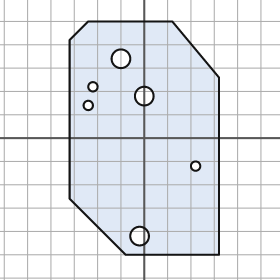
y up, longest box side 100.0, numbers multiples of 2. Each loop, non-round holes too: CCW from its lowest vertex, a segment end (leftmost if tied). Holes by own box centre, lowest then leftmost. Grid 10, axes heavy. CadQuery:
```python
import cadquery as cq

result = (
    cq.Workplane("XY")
    .moveTo(-8.0, -50.0)
    .lineTo(32.0, -50.0)
    .lineTo(32.0, 26.0)
    .lineTo(12.0, 50.0)
    .lineTo(-24.0, 50.0)
    .lineTo(-32.0, 42.0)
    .lineTo(-32.0, -26.0)
    .close()
    .moveTo(-2.0, -42.0)
    .circle(4.0)
    .moveTo(22.0, -12.0)
    .circle(2.0)
    .moveTo(-24.0, 14.0)
    .circle(2.0)
    .moveTo(0.0, 18.0)
    .circle(4.0)
    .moveTo(-22.0, 22.0)
    .circle(2.0)
    .moveTo(-10.0, 34.0)
    .circle(4.0)
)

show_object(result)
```